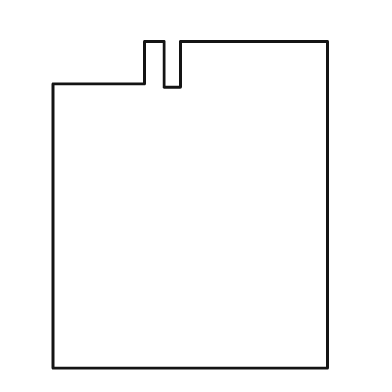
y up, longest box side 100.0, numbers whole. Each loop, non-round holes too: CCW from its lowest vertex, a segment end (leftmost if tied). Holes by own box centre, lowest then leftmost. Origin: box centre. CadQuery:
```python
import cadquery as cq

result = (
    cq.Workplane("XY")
    .moveTo(-42.0, -50.0)
    .lineTo(42.0, -50.0)
    .lineTo(42.0, 50.0)
    .lineTo(-3.0, 50.0)
    .lineTo(-3.0, 36.0)
    .lineTo(-8.0, 36.0)
    .lineTo(-8.0, 50.0)
    .lineTo(-14.0, 50.0)
    .lineTo(-14.0, 37.0)
    .lineTo(-42.0, 37.0)
    .close()
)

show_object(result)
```